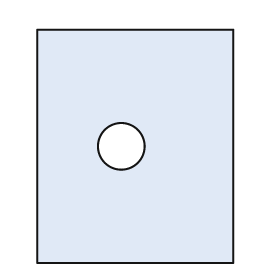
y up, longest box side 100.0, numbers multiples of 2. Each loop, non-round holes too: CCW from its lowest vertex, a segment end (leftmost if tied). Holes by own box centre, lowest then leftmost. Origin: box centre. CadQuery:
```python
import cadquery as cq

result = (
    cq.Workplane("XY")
    .moveTo(-42.0, -50.0)
    .lineTo(42.0, -50.0)
    .lineTo(42.0, 50.0)
    .lineTo(-42.0, 50.0)
    .close()
    .moveTo(-6.0, 0.0)
    .circle(10.0)
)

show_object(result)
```